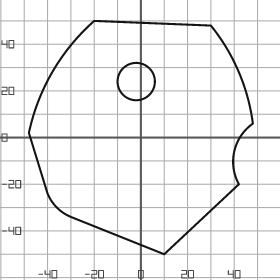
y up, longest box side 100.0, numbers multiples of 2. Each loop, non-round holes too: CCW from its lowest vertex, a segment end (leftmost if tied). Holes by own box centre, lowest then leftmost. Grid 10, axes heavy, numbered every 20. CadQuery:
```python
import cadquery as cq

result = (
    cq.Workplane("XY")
    .moveTo(10.0, -50.0)
    .lineTo(42.0, -20.0)
    .threePointArc((40.0, -6.0), (48.0, 6.0))
    .threePointArc((42.0, 28.0), (30.0, 48.0))
    .lineTo(-20.0, 50.0)
    .threePointArc((-38.0, 28.0), (-48.0, 2.0))
    .lineTo(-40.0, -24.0)
    .threePointArc((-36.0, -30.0), (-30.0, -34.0))
    .close()
    .moveTo(-2.0, 24.0)
    .circle(8.0)
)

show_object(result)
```